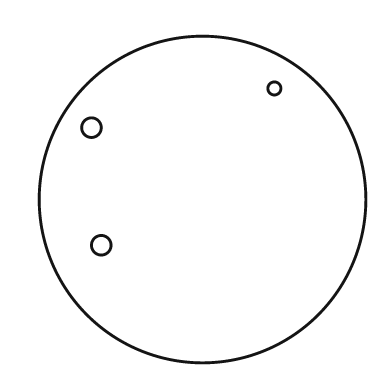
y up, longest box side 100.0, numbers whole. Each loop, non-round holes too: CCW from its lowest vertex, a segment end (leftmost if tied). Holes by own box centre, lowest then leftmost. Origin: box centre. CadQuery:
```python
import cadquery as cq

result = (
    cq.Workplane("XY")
    .moveTo(0.0, 0.0)
    .circle(50.0)
    .moveTo(-31.0, -14.0)
    .circle(3.0)
    .moveTo(-34.0, 22.0)
    .circle(3.0)
    .moveTo(22.0, 34.0)
    .circle(2.0)
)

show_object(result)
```